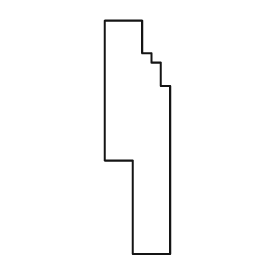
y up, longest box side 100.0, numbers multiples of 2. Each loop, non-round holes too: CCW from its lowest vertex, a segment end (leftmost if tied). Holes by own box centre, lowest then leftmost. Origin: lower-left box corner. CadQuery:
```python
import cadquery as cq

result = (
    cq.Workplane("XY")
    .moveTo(12.0, 0.0)
    .lineTo(28.0, 0.0)
    .lineTo(28.0, 72.0)
    .lineTo(24.0, 72.0)
    .lineTo(24.0, 82.0)
    .lineTo(20.0, 82.0)
    .lineTo(20.0, 86.0)
    .lineTo(16.0, 86.0)
    .lineTo(16.0, 100.0)
    .lineTo(0.0, 100.0)
    .lineTo(0.0, 40.0)
    .lineTo(12.0, 40.0)
    .close()
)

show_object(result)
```